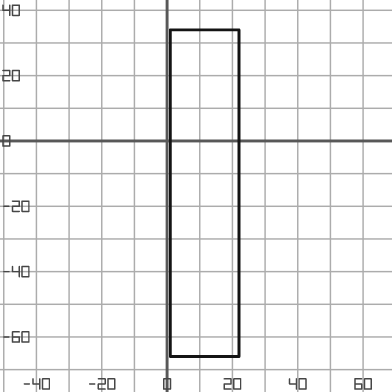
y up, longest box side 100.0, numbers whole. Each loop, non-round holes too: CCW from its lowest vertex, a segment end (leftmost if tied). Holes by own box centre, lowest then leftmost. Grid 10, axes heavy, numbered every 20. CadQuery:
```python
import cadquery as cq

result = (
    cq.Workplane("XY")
    .moveTo(1.0, -66.0)
    .lineTo(22.0, -66.0)
    .lineTo(22.0, 34.0)
    .lineTo(1.0, 34.0)
    .close()
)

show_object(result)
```